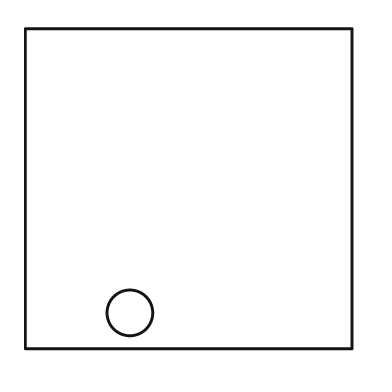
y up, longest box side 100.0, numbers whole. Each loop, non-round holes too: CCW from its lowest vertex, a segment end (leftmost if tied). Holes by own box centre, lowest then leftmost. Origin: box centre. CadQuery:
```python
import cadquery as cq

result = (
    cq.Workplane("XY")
    .moveTo(-50.0, -49.0)
    .lineTo(50.0, -49.0)
    .lineTo(50.0, 49.0)
    .lineTo(-50.0, 49.0)
    .close()
    .moveTo(-18.0, -38.0)
    .circle(7.0)
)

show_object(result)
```